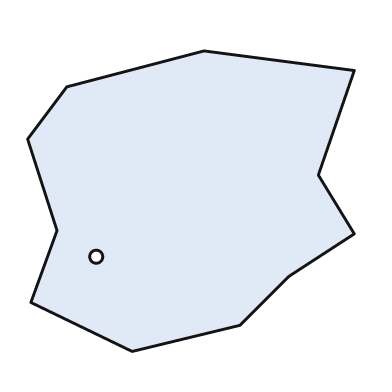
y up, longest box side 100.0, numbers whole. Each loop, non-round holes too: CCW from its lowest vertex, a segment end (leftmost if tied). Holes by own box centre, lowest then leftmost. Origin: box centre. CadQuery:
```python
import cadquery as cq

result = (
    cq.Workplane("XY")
    .moveTo(-18.0, -46.0)
    .lineTo(15.0, -38.0)
    .lineTo(30.0, -23.0)
    .lineTo(50.0, -10.0)
    .lineTo(39.0, 8.0)
    .lineTo(50.0, 40.0)
    .lineTo(4.0, 46.0)
    .lineTo(-38.0, 35.0)
    .lineTo(-50.0, 19.0)
    .lineTo(-41.0, -9.0)
    .lineTo(-49.0, -31.0)
    .close()
    .moveTo(-29.0, -17.0)
    .circle(2.0)
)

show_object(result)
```